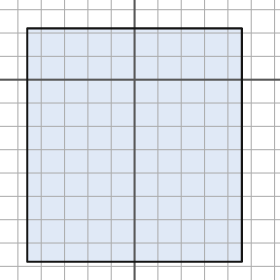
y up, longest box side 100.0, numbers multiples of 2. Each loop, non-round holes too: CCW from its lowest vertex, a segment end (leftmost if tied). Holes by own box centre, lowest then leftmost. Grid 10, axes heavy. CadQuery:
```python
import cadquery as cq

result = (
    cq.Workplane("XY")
    .moveTo(-46.0, -78.0)
    .lineTo(46.0, -78.0)
    .lineTo(46.0, 22.0)
    .lineTo(-46.0, 22.0)
    .close()
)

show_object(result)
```